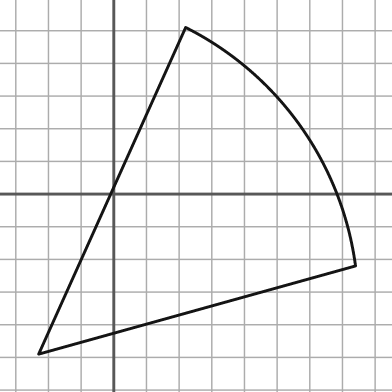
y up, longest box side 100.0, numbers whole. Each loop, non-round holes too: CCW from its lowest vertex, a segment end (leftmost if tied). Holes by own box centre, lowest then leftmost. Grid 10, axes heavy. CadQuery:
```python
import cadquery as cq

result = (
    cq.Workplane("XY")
    .moveTo(-23.0, -49.0)
    .lineTo(74.0, -22.0)
    .threePointArc((57.0, 21.0), (22.0, 51.0))
    .close()
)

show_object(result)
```